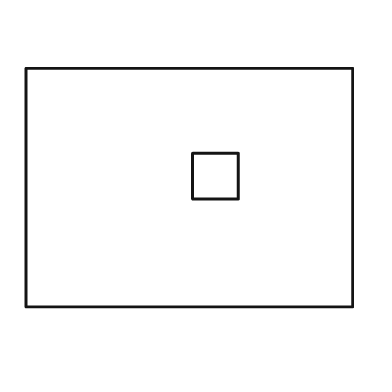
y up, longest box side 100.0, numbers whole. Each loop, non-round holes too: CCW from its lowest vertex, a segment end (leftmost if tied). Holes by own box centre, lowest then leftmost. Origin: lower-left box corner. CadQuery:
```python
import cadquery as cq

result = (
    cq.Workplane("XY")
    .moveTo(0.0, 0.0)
    .lineTo(100.0, 0.0)
    .lineTo(100.0, 73.0)
    .lineTo(0.0, 73.0)
    .close()
    .moveTo(51.0, 33.0)
    .lineTo(65.0, 33.0)
    .lineTo(65.0, 47.0)
    .lineTo(51.0, 47.0)
    .close()
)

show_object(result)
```